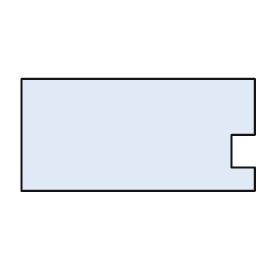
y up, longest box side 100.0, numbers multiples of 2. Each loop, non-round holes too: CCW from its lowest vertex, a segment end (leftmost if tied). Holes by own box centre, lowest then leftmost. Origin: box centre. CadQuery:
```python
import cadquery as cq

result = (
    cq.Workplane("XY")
    .moveTo(-50.0, -24.0)
    .lineTo(50.0, -24.0)
    .lineTo(50.0, -14.0)
    .lineTo(40.0, -14.0)
    .lineTo(40.0, 0.0)
    .lineTo(50.0, 0.0)
    .lineTo(50.0, 24.0)
    .lineTo(-50.0, 24.0)
    .close()
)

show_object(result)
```